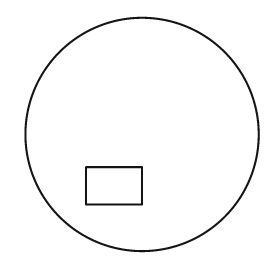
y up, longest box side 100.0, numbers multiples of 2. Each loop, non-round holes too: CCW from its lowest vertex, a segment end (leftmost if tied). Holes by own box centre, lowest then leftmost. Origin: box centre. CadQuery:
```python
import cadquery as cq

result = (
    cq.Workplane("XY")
    .moveTo(0.0, 0.0)
    .circle(50.0)
    .moveTo(-24.0, -30.0)
    .lineTo(0.0, -30.0)
    .lineTo(0.0, -14.0)
    .lineTo(-24.0, -14.0)
    .close()
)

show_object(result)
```